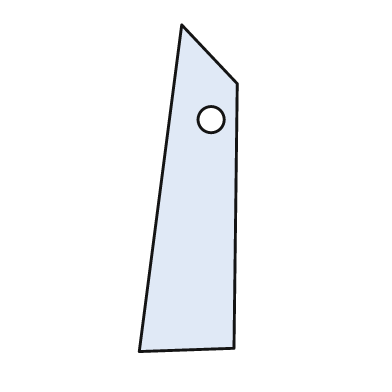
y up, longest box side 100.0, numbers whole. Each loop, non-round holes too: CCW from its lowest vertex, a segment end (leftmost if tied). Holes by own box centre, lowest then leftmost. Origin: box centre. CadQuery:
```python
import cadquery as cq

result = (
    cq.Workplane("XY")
    .moveTo(-15.0, -50.0)
    .lineTo(14.0, -49.0)
    .lineTo(15.0, 32.0)
    .lineTo(-2.0, 50.0)
    .close()
    .moveTo(7.0, 21.0)
    .circle(4.0)
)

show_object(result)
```